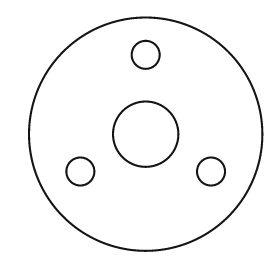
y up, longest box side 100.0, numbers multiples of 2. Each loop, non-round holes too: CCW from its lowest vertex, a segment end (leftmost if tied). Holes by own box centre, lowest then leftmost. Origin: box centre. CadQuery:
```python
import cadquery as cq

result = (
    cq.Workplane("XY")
    .moveTo(0.0, 0.0)
    .circle(50.0)
    .moveTo(-28.0, -16.0)
    .circle(6.0)
    .moveTo(28.0, -16.0)
    .circle(6.0)
    .moveTo(0.0, 0.0)
    .circle(14.0)
    .moveTo(0.0, 34.0)
    .circle(6.0)
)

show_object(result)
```